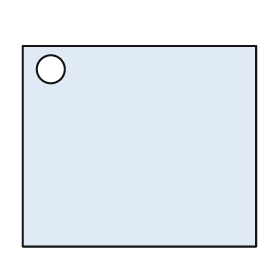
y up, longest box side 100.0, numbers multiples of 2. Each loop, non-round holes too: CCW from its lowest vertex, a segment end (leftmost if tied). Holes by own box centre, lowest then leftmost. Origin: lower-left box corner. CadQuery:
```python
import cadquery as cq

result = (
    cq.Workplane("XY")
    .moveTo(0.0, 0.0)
    .lineTo(100.0, 0.0)
    .lineTo(100.0, 86.0)
    .lineTo(0.0, 86.0)
    .close()
    .moveTo(12.0, 76.0)
    .circle(6.0)
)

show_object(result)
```